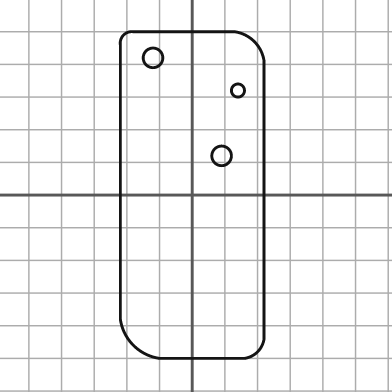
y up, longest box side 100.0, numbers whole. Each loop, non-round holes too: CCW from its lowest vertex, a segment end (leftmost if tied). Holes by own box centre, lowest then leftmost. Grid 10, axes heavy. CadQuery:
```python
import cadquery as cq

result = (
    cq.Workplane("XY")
    .moveTo(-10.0, -50.0)
    .lineTo(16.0, -50.0)
    .threePointArc((20.0, -48.0), (22.0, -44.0))
    .lineTo(22.0, 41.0)
    .threePointArc((19.0, 47.0), (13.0, 50.0))
    .lineTo(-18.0, 50.0)
    .threePointArc((-21.0, 49.0), (-22.0, 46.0))
    .lineTo(-22.0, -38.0)
    .threePointArc((-18.0, -46.0), (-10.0, -50.0))
    .close()
    .moveTo(9.0, 12.0)
    .circle(3.0)
    .moveTo(14.0, 32.0)
    .circle(2.0)
    .moveTo(-12.0, 42.0)
    .circle(3.0)
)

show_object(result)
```